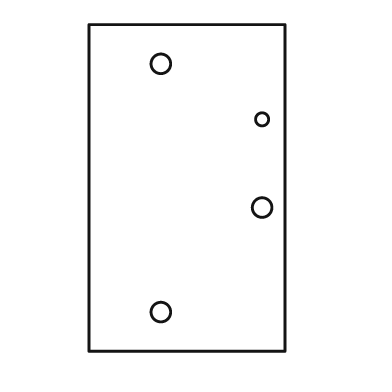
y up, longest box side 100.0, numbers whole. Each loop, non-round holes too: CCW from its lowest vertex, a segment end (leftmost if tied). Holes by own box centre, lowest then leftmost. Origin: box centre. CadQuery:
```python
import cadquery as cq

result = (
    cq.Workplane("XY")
    .moveTo(-30.0, -50.0)
    .lineTo(30.0, -50.0)
    .lineTo(30.0, 50.0)
    .lineTo(-30.0, 50.0)
    .close()
    .moveTo(-8.0, -38.0)
    .circle(3.0)
    .moveTo(23.0, -6.0)
    .circle(3.0)
    .moveTo(23.0, 21.0)
    .circle(2.0)
    .moveTo(-8.0, 38.0)
    .circle(3.0)
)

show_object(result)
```